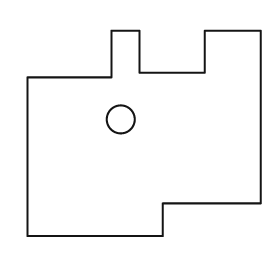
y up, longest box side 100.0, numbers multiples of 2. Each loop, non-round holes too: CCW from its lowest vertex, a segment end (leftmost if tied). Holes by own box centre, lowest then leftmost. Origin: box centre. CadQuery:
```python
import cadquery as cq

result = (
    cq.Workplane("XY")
    .moveTo(-50.0, -44.0)
    .lineTo(8.0, -44.0)
    .lineTo(8.0, -30.0)
    .lineTo(50.0, -30.0)
    .lineTo(50.0, 44.0)
    .lineTo(26.0, 44.0)
    .lineTo(26.0, 26.0)
    .lineTo(-2.0, 26.0)
    .lineTo(-2.0, 44.0)
    .lineTo(-14.0, 44.0)
    .lineTo(-14.0, 24.0)
    .lineTo(-50.0, 24.0)
    .close()
    .moveTo(-10.0, 6.0)
    .circle(6.0)
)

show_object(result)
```